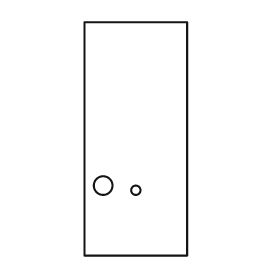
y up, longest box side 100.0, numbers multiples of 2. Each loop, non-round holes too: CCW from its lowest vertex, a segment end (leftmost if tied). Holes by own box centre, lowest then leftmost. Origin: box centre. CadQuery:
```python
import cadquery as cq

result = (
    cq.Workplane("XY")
    .moveTo(-22.0, -50.0)
    .lineTo(22.0, -50.0)
    .lineTo(22.0, 50.0)
    .lineTo(-22.0, 50.0)
    .close()
    .moveTo(0.0, -22.0)
    .circle(2.0)
    .moveTo(-14.0, -20.0)
    .circle(4.0)
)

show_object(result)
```